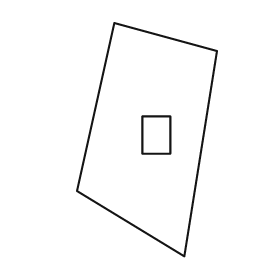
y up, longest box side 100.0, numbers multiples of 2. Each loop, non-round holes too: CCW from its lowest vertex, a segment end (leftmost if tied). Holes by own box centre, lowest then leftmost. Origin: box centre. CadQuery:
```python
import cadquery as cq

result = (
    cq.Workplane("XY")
    .moveTo(16.0, -50.0)
    .lineTo(30.0, 38.0)
    .lineTo(-14.0, 50.0)
    .lineTo(-30.0, -22.0)
    .close()
    .moveTo(-2.0, -6.0)
    .lineTo(10.0, -6.0)
    .lineTo(10.0, 10.0)
    .lineTo(-2.0, 10.0)
    .close()
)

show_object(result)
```